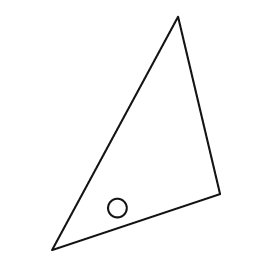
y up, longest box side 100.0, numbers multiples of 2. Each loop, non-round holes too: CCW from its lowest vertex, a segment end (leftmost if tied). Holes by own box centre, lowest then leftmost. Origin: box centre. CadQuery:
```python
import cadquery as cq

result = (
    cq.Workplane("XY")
    .moveTo(-36.0, -50.0)
    .lineTo(36.0, -26.0)
    .lineTo(18.0, 50.0)
    .close()
    .moveTo(-8.0, -32.0)
    .circle(4.0)
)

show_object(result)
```